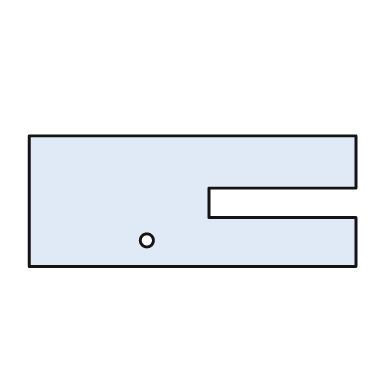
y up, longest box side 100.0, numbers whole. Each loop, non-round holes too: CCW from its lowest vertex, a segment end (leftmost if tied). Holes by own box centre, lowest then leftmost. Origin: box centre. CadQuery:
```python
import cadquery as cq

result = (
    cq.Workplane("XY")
    .moveTo(-50.0, -20.0)
    .lineTo(50.0, -20.0)
    .lineTo(50.0, -5.0)
    .lineTo(5.0, -5.0)
    .lineTo(5.0, 4.0)
    .lineTo(50.0, 4.0)
    .lineTo(50.0, 20.0)
    .lineTo(-50.0, 20.0)
    .close()
    .moveTo(-14.0, -12.0)
    .circle(2.0)
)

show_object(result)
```